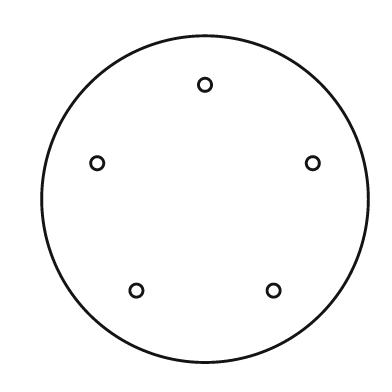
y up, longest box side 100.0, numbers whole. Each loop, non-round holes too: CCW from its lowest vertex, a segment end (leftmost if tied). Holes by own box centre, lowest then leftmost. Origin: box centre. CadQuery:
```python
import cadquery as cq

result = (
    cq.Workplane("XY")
    .moveTo(0.0, 0.0)
    .circle(50.0)
    .moveTo(-21.0, -28.0)
    .circle(2.0)
    .moveTo(21.0, -28.0)
    .circle(2.0)
    .moveTo(-33.0, 11.0)
    .circle(2.0)
    .moveTo(33.0, 11.0)
    .circle(2.0)
    .moveTo(0.0, 35.0)
    .circle(2.0)
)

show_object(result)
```